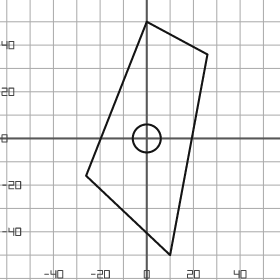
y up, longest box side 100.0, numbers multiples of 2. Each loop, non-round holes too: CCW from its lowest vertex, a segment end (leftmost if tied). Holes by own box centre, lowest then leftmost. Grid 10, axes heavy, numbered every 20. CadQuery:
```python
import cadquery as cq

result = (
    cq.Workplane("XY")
    .moveTo(10.0, -50.0)
    .lineTo(26.0, 36.0)
    .lineTo(0.0, 50.0)
    .lineTo(-26.0, -16.0)
    .close()
    .moveTo(0.0, 0.0)
    .circle(6.0)
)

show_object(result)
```